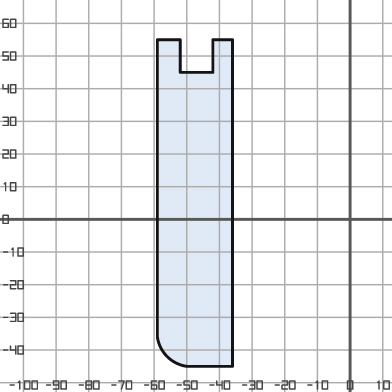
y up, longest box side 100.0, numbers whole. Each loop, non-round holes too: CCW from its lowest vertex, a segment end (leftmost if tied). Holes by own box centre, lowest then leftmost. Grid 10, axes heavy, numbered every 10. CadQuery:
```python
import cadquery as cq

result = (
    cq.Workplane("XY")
    .moveTo(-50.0, -45.0)
    .lineTo(-36.0, -45.0)
    .lineTo(-36.0, 55.0)
    .lineTo(-42.0, 55.0)
    .lineTo(-42.0, 45.0)
    .lineTo(-52.0, 45.0)
    .lineTo(-52.0, 55.0)
    .lineTo(-59.0, 55.0)
    .lineTo(-59.0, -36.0)
    .threePointArc((-56.0, -42.0), (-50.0, -45.0))
    .close()
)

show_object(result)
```